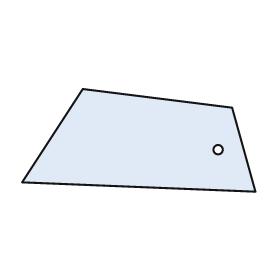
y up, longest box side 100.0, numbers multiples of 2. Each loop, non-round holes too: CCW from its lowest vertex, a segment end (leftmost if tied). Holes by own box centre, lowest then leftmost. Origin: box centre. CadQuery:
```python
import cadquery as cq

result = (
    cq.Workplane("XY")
    .moveTo(50.0, -22.0)
    .lineTo(40.0, 14.0)
    .lineTo(-24.0, 22.0)
    .lineTo(-50.0, -18.0)
    .close()
    .moveTo(34.0, -4.0)
    .circle(2.0)
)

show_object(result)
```